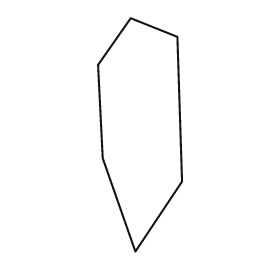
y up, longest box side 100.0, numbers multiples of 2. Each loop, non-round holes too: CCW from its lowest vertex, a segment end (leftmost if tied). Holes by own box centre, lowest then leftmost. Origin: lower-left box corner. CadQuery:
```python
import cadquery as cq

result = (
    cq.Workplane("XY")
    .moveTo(16.0, 0.0)
    .lineTo(36.0, 30.0)
    .lineTo(34.0, 92.0)
    .lineTo(14.0, 100.0)
    .lineTo(0.0, 80.0)
    .lineTo(2.0, 40.0)
    .close()
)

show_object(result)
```